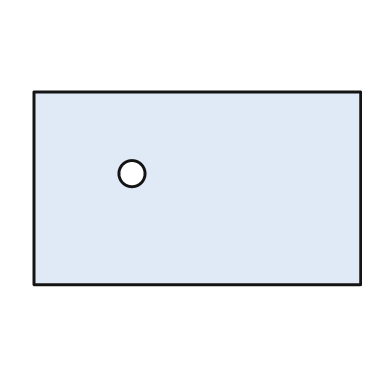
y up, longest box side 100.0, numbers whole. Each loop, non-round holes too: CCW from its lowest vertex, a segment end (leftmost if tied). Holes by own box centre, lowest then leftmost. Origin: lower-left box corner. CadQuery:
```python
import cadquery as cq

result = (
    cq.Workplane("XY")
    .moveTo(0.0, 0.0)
    .lineTo(100.0, 0.0)
    .lineTo(100.0, 59.0)
    .lineTo(0.0, 59.0)
    .close()
    .moveTo(30.0, 34.0)
    .circle(4.0)
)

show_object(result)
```